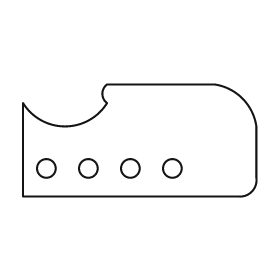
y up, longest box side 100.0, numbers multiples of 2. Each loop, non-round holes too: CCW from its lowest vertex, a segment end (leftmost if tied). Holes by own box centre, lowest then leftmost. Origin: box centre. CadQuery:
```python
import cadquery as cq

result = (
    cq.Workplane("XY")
    .moveTo(-50.0, -24.0)
    .lineTo(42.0, -24.0)
    .threePointArc((48.0, -22.0), (50.0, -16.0))
    .lineTo(50.0, 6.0)
    .threePointArc((44.0, 18.0), (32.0, 24.0))
    .lineTo(-14.0, 24.0)
    .threePointArc((-16.0, 20.0), (-14.0, 16.0))
    .threePointArc((-32.0, 6.0), (-50.0, 16.0))
    .close()
    .moveTo(-40.0, -12.0)
    .circle(4.0)
    .moveTo(-22.0, -12.0)
    .circle(4.0)
    .moveTo(-4.0, -12.0)
    .circle(4.0)
    .moveTo(14.0, -12.0)
    .circle(4.0)
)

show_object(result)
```